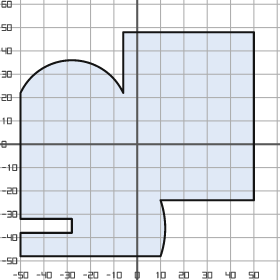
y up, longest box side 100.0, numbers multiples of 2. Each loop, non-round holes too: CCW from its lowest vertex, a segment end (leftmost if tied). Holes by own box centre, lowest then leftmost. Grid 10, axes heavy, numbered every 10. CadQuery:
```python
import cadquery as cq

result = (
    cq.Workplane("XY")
    .moveTo(-50.0, -48.0)
    .lineTo(10.0, -48.0)
    .threePointArc((12.0, -36.0), (10.0, -24.0))
    .lineTo(50.0, -24.0)
    .lineTo(50.0, 48.0)
    .lineTo(-6.0, 48.0)
    .lineTo(-6.0, 22.0)
    .threePointArc((-28.0, 36.0), (-50.0, 22.0))
    .lineTo(-50.0, -32.0)
    .lineTo(-28.0, -32.0)
    .lineTo(-28.0, -38.0)
    .lineTo(-50.0, -38.0)
    .close()
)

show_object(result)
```